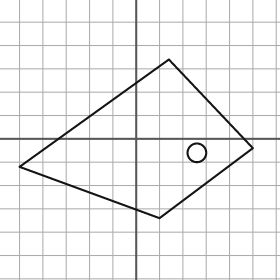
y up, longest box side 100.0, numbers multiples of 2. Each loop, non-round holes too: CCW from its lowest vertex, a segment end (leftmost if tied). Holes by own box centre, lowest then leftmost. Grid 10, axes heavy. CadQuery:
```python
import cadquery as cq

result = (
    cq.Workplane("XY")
    .moveTo(10.0, -34.0)
    .lineTo(50.0, -4.0)
    .lineTo(14.0, 34.0)
    .lineTo(-50.0, -12.0)
    .close()
    .moveTo(26.0, -6.0)
    .circle(4.0)
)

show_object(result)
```